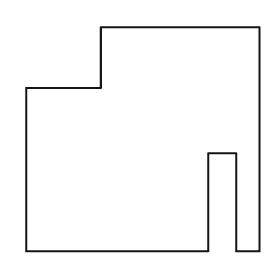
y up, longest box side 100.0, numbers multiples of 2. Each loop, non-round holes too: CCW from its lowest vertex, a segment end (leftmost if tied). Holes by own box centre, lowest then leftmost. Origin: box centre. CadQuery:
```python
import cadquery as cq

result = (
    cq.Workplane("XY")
    .moveTo(-50.0, -48.0)
    .lineTo(28.0, -48.0)
    .lineTo(28.0, -6.0)
    .lineTo(40.0, -6.0)
    .lineTo(40.0, -48.0)
    .lineTo(50.0, -48.0)
    .lineTo(50.0, 48.0)
    .lineTo(-18.0, 48.0)
    .lineTo(-18.0, 22.0)
    .lineTo(-50.0, 22.0)
    .close()
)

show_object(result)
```